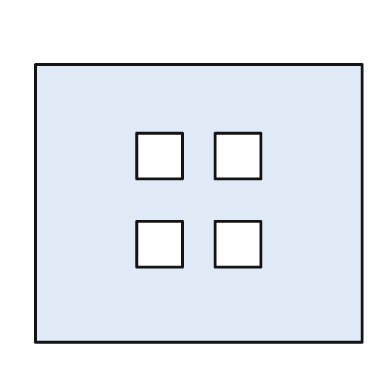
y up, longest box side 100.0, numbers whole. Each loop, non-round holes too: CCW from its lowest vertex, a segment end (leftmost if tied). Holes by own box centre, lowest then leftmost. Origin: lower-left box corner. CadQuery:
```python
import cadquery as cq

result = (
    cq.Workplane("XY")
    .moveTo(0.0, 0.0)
    .lineTo(100.0, 0.0)
    .lineTo(100.0, 85.0)
    .lineTo(0.0, 85.0)
    .close()
    .moveTo(31.0, 23.0)
    .lineTo(45.0, 23.0)
    .lineTo(45.0, 37.0)
    .lineTo(31.0, 37.0)
    .close()
    .moveTo(55.0, 23.0)
    .lineTo(69.0, 23.0)
    .lineTo(69.0, 37.0)
    .lineTo(55.0, 37.0)
    .close()
    .moveTo(31.0, 50.0)
    .lineTo(45.0, 50.0)
    .lineTo(45.0, 64.0)
    .lineTo(31.0, 64.0)
    .close()
    .moveTo(55.0, 50.0)
    .lineTo(69.0, 50.0)
    .lineTo(69.0, 64.0)
    .lineTo(55.0, 64.0)
    .close()
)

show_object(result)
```